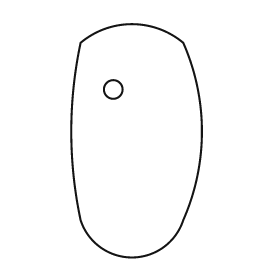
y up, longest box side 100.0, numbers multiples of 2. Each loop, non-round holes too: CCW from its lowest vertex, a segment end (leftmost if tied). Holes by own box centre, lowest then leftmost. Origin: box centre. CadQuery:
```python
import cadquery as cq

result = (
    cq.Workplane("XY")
    .moveTo(-24.0, -34.0)
    .threePointArc((-2.0, -50.0), (20.0, -34.0))
    .threePointArc((28.0, 4.0), (20.0, 42.0))
    .threePointArc((-2.0, 50.0), (-24.0, 42.0))
    .threePointArc((-28.0, 4.0), (-24.0, -34.0))
    .close()
    .moveTo(-10.0, 22.0)
    .circle(4.0)
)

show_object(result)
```